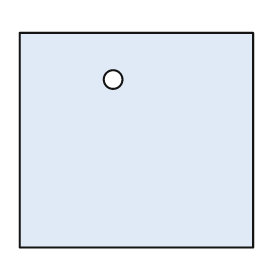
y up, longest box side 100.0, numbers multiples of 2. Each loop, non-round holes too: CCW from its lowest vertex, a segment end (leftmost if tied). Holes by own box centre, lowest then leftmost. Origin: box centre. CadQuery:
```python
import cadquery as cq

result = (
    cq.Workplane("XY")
    .moveTo(-50.0, -46.0)
    .lineTo(50.0, -46.0)
    .lineTo(50.0, 46.0)
    .lineTo(-50.0, 46.0)
    .close()
    .moveTo(-10.0, 26.0)
    .circle(4.0)
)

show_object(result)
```